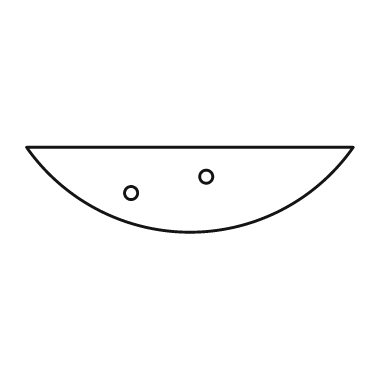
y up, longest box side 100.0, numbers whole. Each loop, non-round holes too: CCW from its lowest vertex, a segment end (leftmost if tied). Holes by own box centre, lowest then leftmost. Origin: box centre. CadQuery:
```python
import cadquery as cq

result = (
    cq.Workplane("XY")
    .moveTo(-50.0, 13.0)
    .threePointArc((0.0, -13.0), (50.0, 13.0))
    .close()
    .moveTo(-18.0, -1.0)
    .circle(2.0)
    .moveTo(5.0, 4.0)
    .circle(2.0)
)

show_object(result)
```